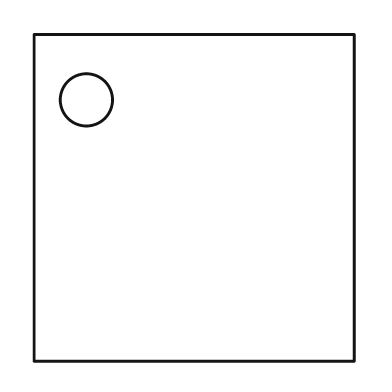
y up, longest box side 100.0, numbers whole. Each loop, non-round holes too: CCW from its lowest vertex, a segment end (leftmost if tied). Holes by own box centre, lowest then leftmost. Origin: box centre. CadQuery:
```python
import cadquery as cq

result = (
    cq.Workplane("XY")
    .moveTo(-49.0, -50.0)
    .lineTo(49.0, -50.0)
    .lineTo(49.0, 50.0)
    .lineTo(-49.0, 50.0)
    .close()
    .moveTo(-33.0, 30.0)
    .circle(8.0)
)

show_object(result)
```